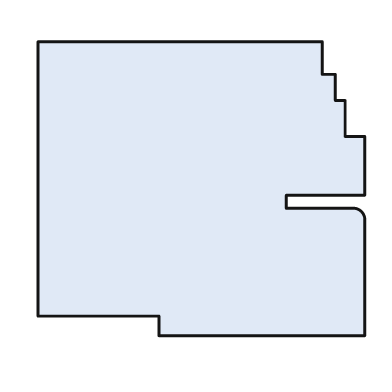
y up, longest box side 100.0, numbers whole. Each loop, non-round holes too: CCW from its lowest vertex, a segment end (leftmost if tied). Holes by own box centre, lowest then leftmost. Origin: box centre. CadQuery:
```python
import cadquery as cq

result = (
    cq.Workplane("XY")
    .moveTo(-13.0, -45.0)
    .lineTo(50.0, -45.0)
    .lineTo(50.0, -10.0)
    .threePointArc((49.0, -7.0), (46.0, -6.0))
    .lineTo(26.0, -6.0)
    .lineTo(26.0, -2.0)
    .lineTo(50.0, -2.0)
    .lineTo(50.0, 16.0)
    .lineTo(44.0, 16.0)
    .lineTo(44.0, 27.0)
    .lineTo(41.0, 27.0)
    .lineTo(41.0, 35.0)
    .lineTo(37.0, 35.0)
    .lineTo(37.0, 45.0)
    .lineTo(-50.0, 45.0)
    .lineTo(-50.0, -39.0)
    .lineTo(-13.0, -39.0)
    .close()
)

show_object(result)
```